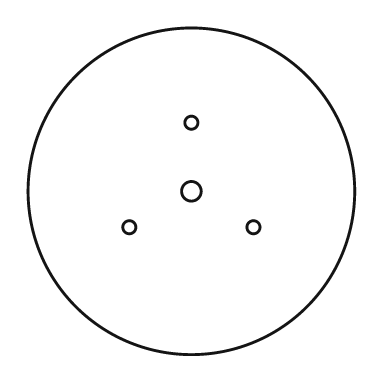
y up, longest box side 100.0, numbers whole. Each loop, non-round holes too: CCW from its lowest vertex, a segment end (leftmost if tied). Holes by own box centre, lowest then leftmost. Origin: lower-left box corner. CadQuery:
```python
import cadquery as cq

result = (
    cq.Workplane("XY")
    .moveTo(50.0, 50.0)
    .circle(50.0)
    .moveTo(31.0, 39.0)
    .circle(2.0)
    .moveTo(69.0, 39.0)
    .circle(2.0)
    .moveTo(50.0, 50.0)
    .circle(3.0)
    .moveTo(50.0, 71.0)
    .circle(2.0)
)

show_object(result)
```